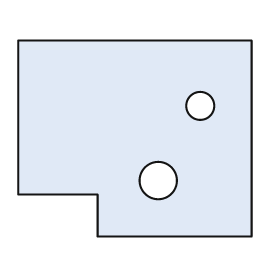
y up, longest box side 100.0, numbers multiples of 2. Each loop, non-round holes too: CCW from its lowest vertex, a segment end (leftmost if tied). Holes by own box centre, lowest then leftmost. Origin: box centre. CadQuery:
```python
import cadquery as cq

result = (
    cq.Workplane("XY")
    .moveTo(-16.0, -42.0)
    .lineTo(50.0, -42.0)
    .lineTo(50.0, 42.0)
    .lineTo(-50.0, 42.0)
    .lineTo(-50.0, -24.0)
    .lineTo(-16.0, -24.0)
    .close()
    .moveTo(10.0, -18.0)
    .circle(8.0)
    .moveTo(28.0, 14.0)
    .circle(6.0)
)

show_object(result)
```